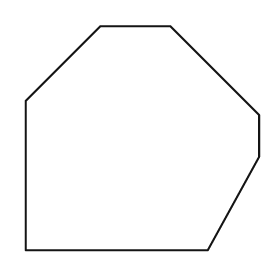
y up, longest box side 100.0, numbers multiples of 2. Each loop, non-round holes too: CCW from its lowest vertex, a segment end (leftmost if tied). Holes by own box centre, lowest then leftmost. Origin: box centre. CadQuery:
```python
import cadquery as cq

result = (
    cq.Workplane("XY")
    .moveTo(-50.0, -48.0)
    .lineTo(28.0, -48.0)
    .lineTo(50.0, -8.0)
    .lineTo(50.0, 10.0)
    .lineTo(12.0, 48.0)
    .lineTo(-18.0, 48.0)
    .lineTo(-50.0, 16.0)
    .close()
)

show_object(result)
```